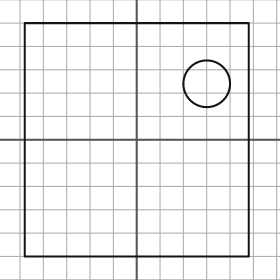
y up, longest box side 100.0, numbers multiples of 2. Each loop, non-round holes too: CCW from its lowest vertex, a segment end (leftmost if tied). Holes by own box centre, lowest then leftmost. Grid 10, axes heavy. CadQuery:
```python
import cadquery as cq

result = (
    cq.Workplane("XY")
    .moveTo(-48.0, -50.0)
    .lineTo(48.0, -50.0)
    .lineTo(48.0, 50.0)
    .lineTo(-48.0, 50.0)
    .close()
    .moveTo(30.0, 24.0)
    .circle(10.0)
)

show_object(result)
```